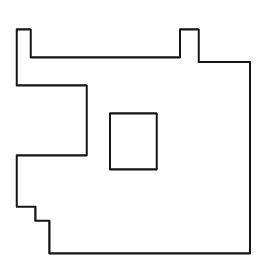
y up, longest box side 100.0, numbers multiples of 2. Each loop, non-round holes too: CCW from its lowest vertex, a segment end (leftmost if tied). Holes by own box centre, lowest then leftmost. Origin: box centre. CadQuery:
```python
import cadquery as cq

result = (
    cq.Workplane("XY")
    .moveTo(-36.0, -48.0)
    .lineTo(50.0, -48.0)
    .lineTo(50.0, 34.0)
    .lineTo(28.0, 34.0)
    .lineTo(28.0, 48.0)
    .lineTo(20.0, 48.0)
    .lineTo(20.0, 36.0)
    .lineTo(-44.0, 36.0)
    .lineTo(-44.0, 48.0)
    .lineTo(-50.0, 48.0)
    .lineTo(-50.0, 24.0)
    .lineTo(-20.0, 24.0)
    .lineTo(-20.0, -6.0)
    .lineTo(-50.0, -6.0)
    .lineTo(-50.0, -28.0)
    .lineTo(-42.0, -28.0)
    .lineTo(-42.0, -34.0)
    .lineTo(-36.0, -34.0)
    .close()
    .moveTo(-10.0, -12.0)
    .lineTo(10.0, -12.0)
    .lineTo(10.0, 12.0)
    .lineTo(-10.0, 12.0)
    .close()
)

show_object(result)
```